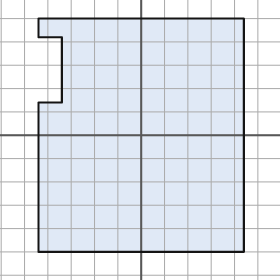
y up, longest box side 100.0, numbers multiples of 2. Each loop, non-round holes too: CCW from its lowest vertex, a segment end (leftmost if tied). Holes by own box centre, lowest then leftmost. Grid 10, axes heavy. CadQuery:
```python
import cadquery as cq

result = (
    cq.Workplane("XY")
    .moveTo(-44.0, -50.0)
    .lineTo(44.0, -50.0)
    .lineTo(44.0, 50.0)
    .lineTo(-44.0, 50.0)
    .lineTo(-44.0, 42.0)
    .lineTo(-34.0, 42.0)
    .lineTo(-34.0, 14.0)
    .lineTo(-44.0, 14.0)
    .close()
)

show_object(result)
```